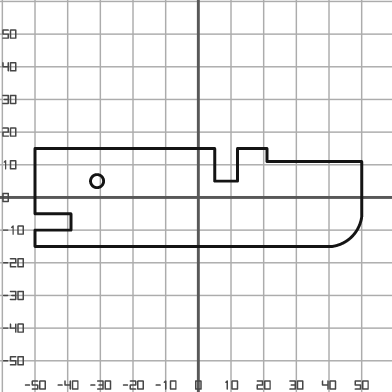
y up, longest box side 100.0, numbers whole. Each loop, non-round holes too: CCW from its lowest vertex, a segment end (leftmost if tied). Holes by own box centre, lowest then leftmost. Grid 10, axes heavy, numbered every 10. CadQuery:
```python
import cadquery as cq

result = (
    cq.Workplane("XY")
    .moveTo(-50.0, -15.0)
    .lineTo(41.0, -15.0)
    .threePointArc((47.0, -12.0), (50.0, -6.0))
    .lineTo(50.0, 11.0)
    .lineTo(21.0, 11.0)
    .lineTo(21.0, 15.0)
    .lineTo(12.0, 15.0)
    .lineTo(12.0, 5.0)
    .lineTo(5.0, 5.0)
    .lineTo(5.0, 15.0)
    .lineTo(-50.0, 15.0)
    .lineTo(-50.0, -5.0)
    .lineTo(-39.0, -5.0)
    .lineTo(-39.0, -10.0)
    .lineTo(-50.0, -10.0)
    .close()
    .moveTo(-31.0, 5.0)
    .circle(2.0)
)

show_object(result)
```